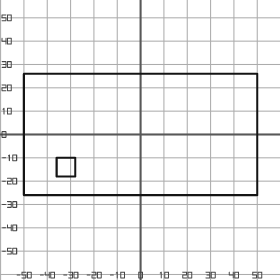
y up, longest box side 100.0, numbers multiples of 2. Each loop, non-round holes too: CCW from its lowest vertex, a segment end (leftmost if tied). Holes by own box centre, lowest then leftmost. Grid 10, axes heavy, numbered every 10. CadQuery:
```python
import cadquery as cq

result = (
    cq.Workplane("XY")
    .moveTo(-50.0, -26.0)
    .lineTo(50.0, -26.0)
    .lineTo(50.0, 26.0)
    .lineTo(-50.0, 26.0)
    .close()
    .moveTo(-36.0, -18.0)
    .lineTo(-28.0, -18.0)
    .lineTo(-28.0, -10.0)
    .lineTo(-36.0, -10.0)
    .close()
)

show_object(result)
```